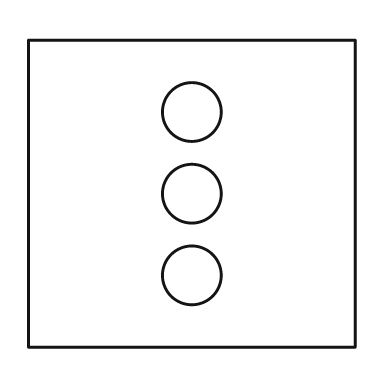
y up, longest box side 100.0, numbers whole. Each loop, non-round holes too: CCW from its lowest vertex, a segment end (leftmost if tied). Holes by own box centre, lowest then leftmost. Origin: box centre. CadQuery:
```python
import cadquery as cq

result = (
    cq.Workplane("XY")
    .moveTo(-50.0, -47.0)
    .lineTo(50.0, -47.0)
    .lineTo(50.0, 47.0)
    .lineTo(-50.0, 47.0)
    .close()
    .moveTo(0.0, -25.0)
    .circle(9.0)
    .moveTo(0.0, 0.0)
    .circle(9.0)
    .moveTo(0.0, 25.0)
    .circle(9.0)
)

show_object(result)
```